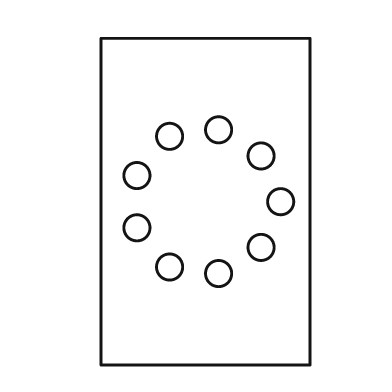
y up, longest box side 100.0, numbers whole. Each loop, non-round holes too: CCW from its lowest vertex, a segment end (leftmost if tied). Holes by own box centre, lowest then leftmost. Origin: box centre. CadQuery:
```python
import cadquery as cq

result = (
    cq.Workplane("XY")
    .moveTo(-32.0, -50.0)
    .lineTo(32.0, -50.0)
    .lineTo(32.0, 50.0)
    .lineTo(-32.0, 50.0)
    .close()
    .moveTo(4.0, -22.0)
    .circle(4.0)
    .moveTo(-11.0, -20.0)
    .circle(4.0)
    .moveTo(17.0, -14.0)
    .circle(4.0)
    .moveTo(-21.0, -8.0)
    .circle(4.0)
    .moveTo(23.0, 0.0)
    .circle(4.0)
    .moveTo(-21.0, 8.0)
    .circle(4.0)
    .moveTo(17.0, 14.0)
    .circle(4.0)
    .moveTo(-11.0, 20.0)
    .circle(4.0)
    .moveTo(4.0, 22.0)
    .circle(4.0)
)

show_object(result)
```